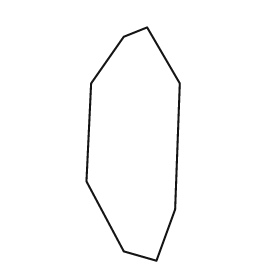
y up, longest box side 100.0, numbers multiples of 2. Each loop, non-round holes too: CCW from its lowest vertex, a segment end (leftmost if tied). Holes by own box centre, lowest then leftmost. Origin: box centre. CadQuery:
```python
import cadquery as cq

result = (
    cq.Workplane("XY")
    .moveTo(10.0, -50.0)
    .lineTo(18.0, -28.0)
    .lineTo(20.0, 26.0)
    .lineTo(6.0, 50.0)
    .lineTo(-4.0, 46.0)
    .lineTo(-18.0, 26.0)
    .lineTo(-20.0, -16.0)
    .lineTo(-4.0, -46.0)
    .close()
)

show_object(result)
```